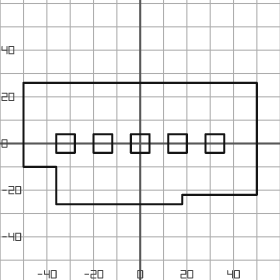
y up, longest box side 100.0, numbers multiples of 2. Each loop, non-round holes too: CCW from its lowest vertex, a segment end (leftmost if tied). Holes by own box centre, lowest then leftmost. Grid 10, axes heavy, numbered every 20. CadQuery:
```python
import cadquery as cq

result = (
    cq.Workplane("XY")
    .moveTo(-36.0, -26.0)
    .lineTo(18.0, -26.0)
    .lineTo(18.0, -22.0)
    .lineTo(50.0, -22.0)
    .lineTo(50.0, 26.0)
    .lineTo(-50.0, 26.0)
    .lineTo(-50.0, -10.0)
    .lineTo(-36.0, -10.0)
    .close()
    .moveTo(-36.0, -4.0)
    .lineTo(-28.0, -4.0)
    .lineTo(-28.0, 4.0)
    .lineTo(-36.0, 4.0)
    .close()
    .moveTo(-20.0, -4.0)
    .lineTo(-12.0, -4.0)
    .lineTo(-12.0, 4.0)
    .lineTo(-20.0, 4.0)
    .close()
    .moveTo(-4.0, -4.0)
    .lineTo(4.0, -4.0)
    .lineTo(4.0, 4.0)
    .lineTo(-4.0, 4.0)
    .close()
    .moveTo(12.0, -4.0)
    .lineTo(20.0, -4.0)
    .lineTo(20.0, 4.0)
    .lineTo(12.0, 4.0)
    .close()
    .moveTo(28.0, -4.0)
    .lineTo(36.0, -4.0)
    .lineTo(36.0, 4.0)
    .lineTo(28.0, 4.0)
    .close()
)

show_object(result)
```